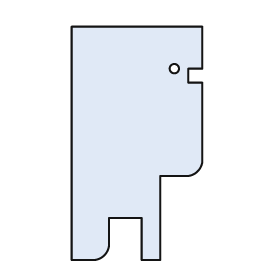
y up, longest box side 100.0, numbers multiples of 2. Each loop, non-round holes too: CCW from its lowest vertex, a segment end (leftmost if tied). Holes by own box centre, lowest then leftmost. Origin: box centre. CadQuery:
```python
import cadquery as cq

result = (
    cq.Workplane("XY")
    .moveTo(-28.0, -50.0)
    .lineTo(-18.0, -50.0)
    .threePointArc((-14.0, -48.0), (-12.0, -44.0))
    .lineTo(-12.0, -32.0)
    .lineTo(2.0, -32.0)
    .lineTo(2.0, -50.0)
    .lineTo(10.0, -50.0)
    .lineTo(10.0, -14.0)
    .lineTo(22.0, -14.0)
    .threePointArc((26.0, -12.0), (28.0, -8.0))
    .lineTo(28.0, 26.0)
    .lineTo(22.0, 26.0)
    .lineTo(22.0, 32.0)
    .lineTo(28.0, 32.0)
    .lineTo(28.0, 50.0)
    .lineTo(-28.0, 50.0)
    .close()
    .moveTo(16.0, 32.0)
    .circle(2.0)
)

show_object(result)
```